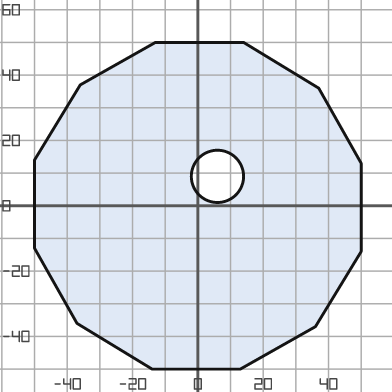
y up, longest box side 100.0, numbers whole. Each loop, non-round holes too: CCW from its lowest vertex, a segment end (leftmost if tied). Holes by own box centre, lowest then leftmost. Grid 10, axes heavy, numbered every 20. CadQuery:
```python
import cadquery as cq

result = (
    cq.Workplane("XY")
    .moveTo(-14.0, -50.0)
    .lineTo(13.0, -50.0)
    .lineTo(36.0, -37.0)
    .lineTo(50.0, -14.0)
    .lineTo(50.0, 13.0)
    .lineTo(37.0, 36.0)
    .lineTo(14.0, 50.0)
    .lineTo(-13.0, 50.0)
    .lineTo(-36.0, 37.0)
    .lineTo(-50.0, 14.0)
    .lineTo(-50.0, -13.0)
    .lineTo(-37.0, -36.0)
    .close()
    .moveTo(6.0, 9.0)
    .circle(8.0)
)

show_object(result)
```